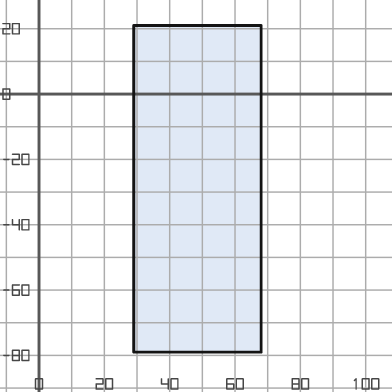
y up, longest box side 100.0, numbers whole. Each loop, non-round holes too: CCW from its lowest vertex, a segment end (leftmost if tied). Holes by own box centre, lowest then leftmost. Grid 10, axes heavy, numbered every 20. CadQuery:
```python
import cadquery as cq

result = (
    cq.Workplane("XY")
    .moveTo(29.0, -79.0)
    .lineTo(68.0, -79.0)
    .lineTo(68.0, 21.0)
    .lineTo(29.0, 21.0)
    .close()
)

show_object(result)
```